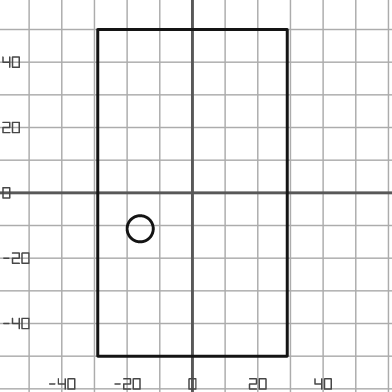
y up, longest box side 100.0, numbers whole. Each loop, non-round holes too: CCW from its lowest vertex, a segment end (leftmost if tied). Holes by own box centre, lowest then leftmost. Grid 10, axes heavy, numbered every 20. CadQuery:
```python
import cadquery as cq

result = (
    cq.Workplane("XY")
    .moveTo(-29.0, -50.0)
    .lineTo(29.0, -50.0)
    .lineTo(29.0, 50.0)
    .lineTo(-29.0, 50.0)
    .close()
    .moveTo(-16.0, -11.0)
    .circle(4.0)
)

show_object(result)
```